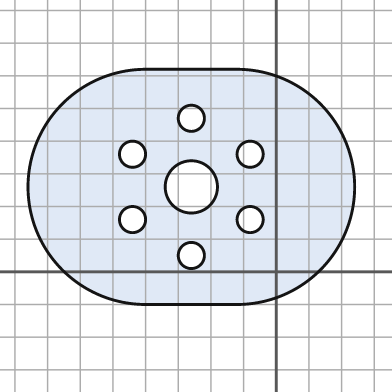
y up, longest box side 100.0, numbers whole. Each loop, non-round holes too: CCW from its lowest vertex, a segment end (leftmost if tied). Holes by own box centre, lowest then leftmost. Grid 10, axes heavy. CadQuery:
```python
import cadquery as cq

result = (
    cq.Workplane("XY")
    .moveTo(-40.0, -10.0)
    .lineTo(-12.0, -10.0)
    .threePointArc((24.0, 26.0), (-12.0, 62.0))
    .lineTo(-40.0, 62.0)
    .threePointArc((-76.0, 26.0), (-40.0, -10.0))
    .close()
    .moveTo(-26.0, 5.0)
    .circle(4.0)
    .moveTo(-44.0, 16.0)
    .circle(4.0)
    .moveTo(-8.0, 16.0)
    .circle(4.0)
    .moveTo(-26.0, 26.0)
    .circle(8.0)
    .moveTo(-44.0, 36.0)
    .circle(4.0)
    .moveTo(-8.0, 36.0)
    .circle(4.0)
    .moveTo(-26.0, 47.0)
    .circle(4.0)
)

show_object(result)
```